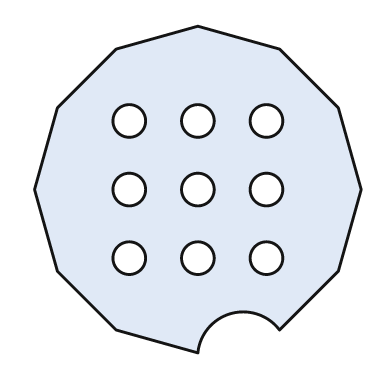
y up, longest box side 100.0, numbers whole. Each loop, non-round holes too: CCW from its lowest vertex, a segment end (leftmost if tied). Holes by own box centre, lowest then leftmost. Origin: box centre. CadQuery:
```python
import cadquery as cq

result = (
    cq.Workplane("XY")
    .moveTo(0.0, -50.0)
    .threePointArc((10.0, -38.0), (25.0, -43.0))
    .lineTo(43.0, -25.0)
    .lineTo(50.0, 0.0)
    .lineTo(43.0, 25.0)
    .lineTo(25.0, 43.0)
    .lineTo(0.0, 50.0)
    .lineTo(-25.0, 43.0)
    .lineTo(-43.0, 25.0)
    .lineTo(-50.0, 0.0)
    .lineTo(-43.0, -25.0)
    .lineTo(-25.0, -43.0)
    .close()
    .moveTo(-21.0, -21.0)
    .circle(5.0)
    .moveTo(0.0, -21.0)
    .circle(5.0)
    .moveTo(21.0, -21.0)
    .circle(5.0)
    .moveTo(-21.0, 0.0)
    .circle(5.0)
    .moveTo(0.0, 0.0)
    .circle(5.0)
    .moveTo(21.0, 0.0)
    .circle(5.0)
    .moveTo(-21.0, 21.0)
    .circle(5.0)
    .moveTo(0.0, 21.0)
    .circle(5.0)
    .moveTo(21.0, 21.0)
    .circle(5.0)
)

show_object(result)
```